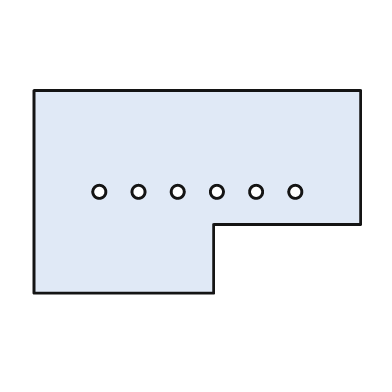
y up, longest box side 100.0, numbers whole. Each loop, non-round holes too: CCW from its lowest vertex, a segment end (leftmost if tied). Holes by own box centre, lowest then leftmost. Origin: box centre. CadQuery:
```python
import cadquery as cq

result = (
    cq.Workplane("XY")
    .moveTo(-50.0, -31.0)
    .lineTo(5.0, -31.0)
    .lineTo(5.0, -10.0)
    .lineTo(50.0, -10.0)
    .lineTo(50.0, 31.0)
    .lineTo(-50.0, 31.0)
    .close()
    .moveTo(-30.0, 0.0)
    .circle(2.0)
    .moveTo(-18.0, 0.0)
    .circle(2.0)
    .moveTo(-6.0, 0.0)
    .circle(2.0)
    .moveTo(6.0, 0.0)
    .circle(2.0)
    .moveTo(18.0, 0.0)
    .circle(2.0)
    .moveTo(30.0, 0.0)
    .circle(2.0)
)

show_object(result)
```